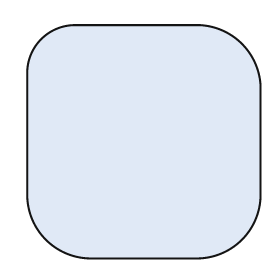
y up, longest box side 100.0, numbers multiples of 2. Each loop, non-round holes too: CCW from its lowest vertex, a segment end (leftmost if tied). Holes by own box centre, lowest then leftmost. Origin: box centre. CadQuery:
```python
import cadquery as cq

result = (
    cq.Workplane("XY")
    .moveTo(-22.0, -50.0)
    .lineTo(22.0, -50.0)
    .threePointArc((42.0, -42.0), (50.0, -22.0))
    .lineTo(50.0, 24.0)
    .threePointArc((42.0, 42.0), (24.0, 50.0))
    .lineTo(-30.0, 50.0)
    .threePointArc((-44.0, 44.0), (-50.0, 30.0))
    .lineTo(-50.0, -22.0)
    .threePointArc((-42.0, -42.0), (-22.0, -50.0))
    .close()
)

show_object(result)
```